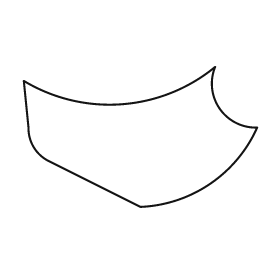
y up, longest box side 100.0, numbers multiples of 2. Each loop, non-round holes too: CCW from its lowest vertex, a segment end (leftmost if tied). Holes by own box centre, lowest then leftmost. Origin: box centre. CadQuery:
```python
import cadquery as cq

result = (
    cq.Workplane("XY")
    .moveTo(0.0, -30.0)
    .threePointArc((30.0, -20.0), (50.0, 4.0))
    .threePointArc((34.0, 12.0), (32.0, 30.0))
    .threePointArc((-8.0, 14.0), (-50.0, 24.0))
    .lineTo(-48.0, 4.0)
    .threePointArc((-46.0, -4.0), (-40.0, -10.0))
    .close()
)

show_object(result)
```